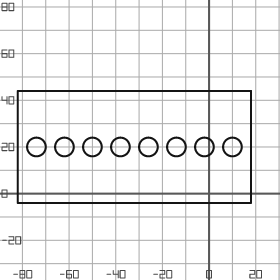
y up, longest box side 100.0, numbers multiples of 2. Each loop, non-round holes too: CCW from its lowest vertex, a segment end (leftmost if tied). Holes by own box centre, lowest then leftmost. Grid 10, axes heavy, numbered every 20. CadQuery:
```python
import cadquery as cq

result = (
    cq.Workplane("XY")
    .moveTo(-82.0, -4.0)
    .lineTo(18.0, -4.0)
    .lineTo(18.0, 44.0)
    .lineTo(-82.0, 44.0)
    .close()
    .moveTo(-74.0, 20.0)
    .circle(4.0)
    .moveTo(-62.0, 20.0)
    .circle(4.0)
    .moveTo(-50.0, 20.0)
    .circle(4.0)
    .moveTo(-38.0, 20.0)
    .circle(4.0)
    .moveTo(-26.0, 20.0)
    .circle(4.0)
    .moveTo(-14.0, 20.0)
    .circle(4.0)
    .moveTo(-2.0, 20.0)
    .circle(4.0)
    .moveTo(10.0, 20.0)
    .circle(4.0)
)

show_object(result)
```